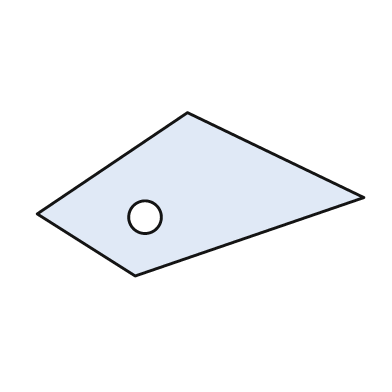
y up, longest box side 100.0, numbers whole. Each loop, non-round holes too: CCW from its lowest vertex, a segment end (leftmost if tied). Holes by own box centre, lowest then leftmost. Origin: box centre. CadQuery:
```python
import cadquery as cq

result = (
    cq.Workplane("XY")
    .moveTo(-20.0, -25.0)
    .lineTo(50.0, -1.0)
    .lineTo(-4.0, 25.0)
    .lineTo(-50.0, -6.0)
    .close()
    .moveTo(-17.0, -7.0)
    .circle(5.0)
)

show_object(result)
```